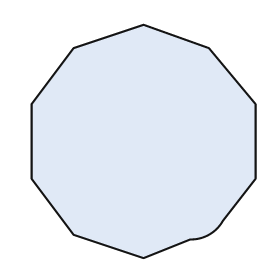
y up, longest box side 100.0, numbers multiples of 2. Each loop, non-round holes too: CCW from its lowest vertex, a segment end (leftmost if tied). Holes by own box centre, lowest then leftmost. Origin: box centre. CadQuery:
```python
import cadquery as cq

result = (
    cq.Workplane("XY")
    .moveTo(0.0, -50.0)
    .lineTo(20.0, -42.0)
    .threePointArc((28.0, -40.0), (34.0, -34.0))
    .lineTo(48.0, -16.0)
    .lineTo(48.0, 16.0)
    .lineTo(28.0, 40.0)
    .lineTo(0.0, 50.0)
    .lineTo(-30.0, 40.0)
    .lineTo(-48.0, 16.0)
    .lineTo(-48.0, -16.0)
    .lineTo(-30.0, -40.0)
    .close()
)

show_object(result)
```